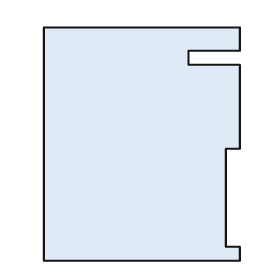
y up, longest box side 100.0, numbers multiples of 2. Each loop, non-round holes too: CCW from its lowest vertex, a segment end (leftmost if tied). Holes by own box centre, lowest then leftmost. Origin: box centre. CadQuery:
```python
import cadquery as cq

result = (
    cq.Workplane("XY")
    .moveTo(-42.0, -50.0)
    .lineTo(42.0, -50.0)
    .lineTo(42.0, -44.0)
    .lineTo(36.0, -44.0)
    .lineTo(36.0, -2.0)
    .lineTo(42.0, -2.0)
    .lineTo(42.0, 34.0)
    .lineTo(20.0, 34.0)
    .lineTo(20.0, 40.0)
    .lineTo(42.0, 40.0)
    .lineTo(42.0, 50.0)
    .lineTo(-42.0, 50.0)
    .close()
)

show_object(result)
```